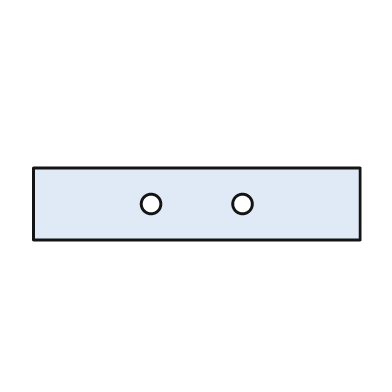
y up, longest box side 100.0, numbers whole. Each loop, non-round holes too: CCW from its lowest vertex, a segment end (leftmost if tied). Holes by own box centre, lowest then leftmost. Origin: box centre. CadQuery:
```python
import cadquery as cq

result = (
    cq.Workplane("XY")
    .moveTo(-50.0, -11.0)
    .lineTo(50.0, -11.0)
    .lineTo(50.0, 11.0)
    .lineTo(-50.0, 11.0)
    .close()
    .moveTo(-14.0, 0.0)
    .circle(3.0)
    .moveTo(14.0, 0.0)
    .circle(3.0)
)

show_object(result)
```